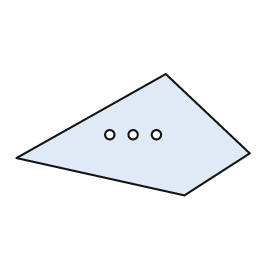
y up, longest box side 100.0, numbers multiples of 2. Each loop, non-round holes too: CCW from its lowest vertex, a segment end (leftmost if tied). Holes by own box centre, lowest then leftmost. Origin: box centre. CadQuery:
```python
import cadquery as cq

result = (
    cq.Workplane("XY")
    .moveTo(22.0, -26.0)
    .lineTo(50.0, -8.0)
    .lineTo(14.0, 26.0)
    .lineTo(-50.0, -10.0)
    .close()
    .moveTo(-10.0, 0.0)
    .circle(2.0)
    .moveTo(0.0, 0.0)
    .circle(2.0)
    .moveTo(10.0, 0.0)
    .circle(2.0)
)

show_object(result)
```